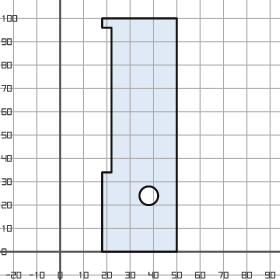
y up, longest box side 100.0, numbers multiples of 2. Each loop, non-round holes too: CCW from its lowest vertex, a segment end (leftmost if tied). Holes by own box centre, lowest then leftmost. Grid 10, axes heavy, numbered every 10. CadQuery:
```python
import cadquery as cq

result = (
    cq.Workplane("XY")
    .moveTo(18.0, 0.0)
    .lineTo(50.0, 0.0)
    .lineTo(50.0, 100.0)
    .lineTo(18.0, 100.0)
    .lineTo(18.0, 96.0)
    .lineTo(22.0, 96.0)
    .lineTo(22.0, 34.0)
    .lineTo(18.0, 34.0)
    .close()
    .moveTo(38.0, 24.0)
    .circle(4.0)
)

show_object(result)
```